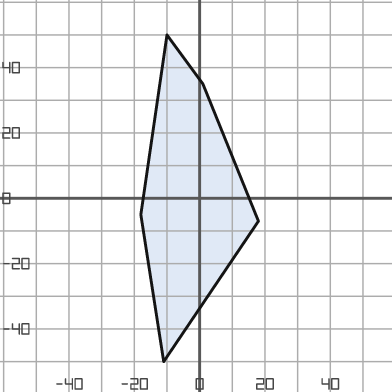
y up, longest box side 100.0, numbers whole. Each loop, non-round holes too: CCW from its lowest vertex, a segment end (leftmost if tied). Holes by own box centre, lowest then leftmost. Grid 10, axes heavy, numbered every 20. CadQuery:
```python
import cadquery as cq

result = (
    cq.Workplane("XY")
    .moveTo(-11.0, -50.0)
    .lineTo(18.0, -7.0)
    .lineTo(1.0, 35.0)
    .lineTo(-10.0, 50.0)
    .lineTo(-18.0, -5.0)
    .close()
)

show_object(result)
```